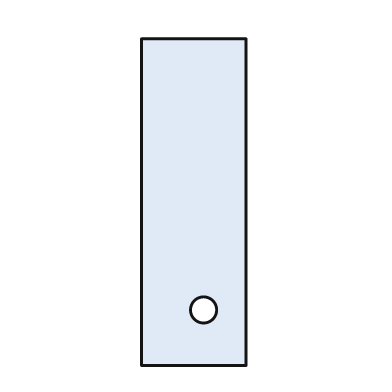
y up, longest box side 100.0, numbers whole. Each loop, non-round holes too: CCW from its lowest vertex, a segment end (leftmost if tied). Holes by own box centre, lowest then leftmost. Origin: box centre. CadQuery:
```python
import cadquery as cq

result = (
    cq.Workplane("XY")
    .moveTo(-16.0, -50.0)
    .lineTo(16.0, -50.0)
    .lineTo(16.0, 50.0)
    .lineTo(-16.0, 50.0)
    .close()
    .moveTo(3.0, -33.0)
    .circle(4.0)
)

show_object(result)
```